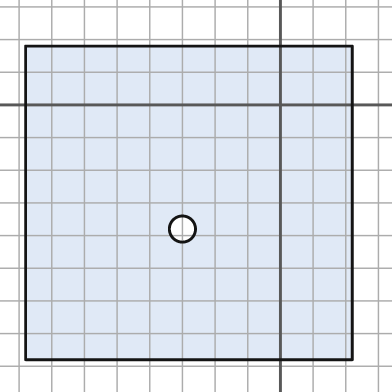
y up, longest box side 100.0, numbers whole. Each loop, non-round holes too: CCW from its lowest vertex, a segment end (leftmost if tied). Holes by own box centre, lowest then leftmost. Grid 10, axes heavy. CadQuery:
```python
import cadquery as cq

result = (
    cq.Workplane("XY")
    .moveTo(-78.0, -78.0)
    .lineTo(22.0, -78.0)
    .lineTo(22.0, 18.0)
    .lineTo(-78.0, 18.0)
    .close()
    .moveTo(-30.0, -38.0)
    .circle(4.0)
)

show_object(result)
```